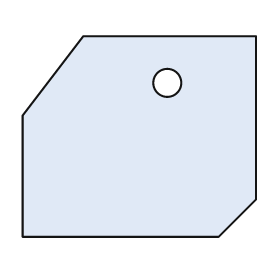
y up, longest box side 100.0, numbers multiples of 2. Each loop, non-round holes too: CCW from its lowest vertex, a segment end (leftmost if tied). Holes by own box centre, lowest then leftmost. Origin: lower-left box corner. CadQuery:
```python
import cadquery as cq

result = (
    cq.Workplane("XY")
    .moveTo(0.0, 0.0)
    .lineTo(84.0, 0.0)
    .lineTo(100.0, 16.0)
    .lineTo(100.0, 86.0)
    .lineTo(26.0, 86.0)
    .lineTo(0.0, 52.0)
    .close()
    .moveTo(62.0, 66.0)
    .circle(6.0)
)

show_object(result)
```